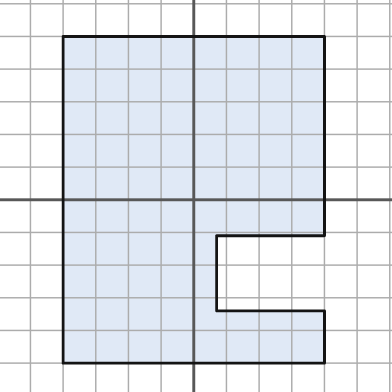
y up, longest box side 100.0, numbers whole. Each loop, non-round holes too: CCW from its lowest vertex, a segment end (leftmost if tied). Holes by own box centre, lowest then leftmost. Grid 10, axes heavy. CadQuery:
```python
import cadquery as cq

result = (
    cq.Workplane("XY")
    .moveTo(-40.0, -50.0)
    .lineTo(40.0, -50.0)
    .lineTo(40.0, -34.0)
    .lineTo(7.0, -34.0)
    .lineTo(7.0, -11.0)
    .lineTo(40.0, -11.0)
    .lineTo(40.0, 50.0)
    .lineTo(-40.0, 50.0)
    .close()
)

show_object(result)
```